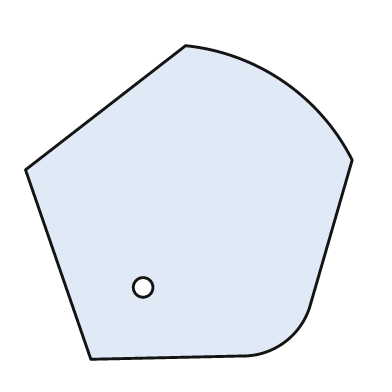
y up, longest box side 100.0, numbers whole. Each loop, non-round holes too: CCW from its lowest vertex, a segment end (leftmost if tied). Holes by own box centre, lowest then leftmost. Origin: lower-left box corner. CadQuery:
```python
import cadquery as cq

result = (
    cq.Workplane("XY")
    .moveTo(20.0, 0.0)
    .lineTo(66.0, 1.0)
    .threePointArc((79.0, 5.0), (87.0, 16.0))
    .lineTo(100.0, 61.0)
    .threePointArc((79.0, 85.0), (49.0, 96.0))
    .lineTo(0.0, 58.0)
    .close()
    .moveTo(36.0, 22.0)
    .circle(3.0)
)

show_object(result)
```